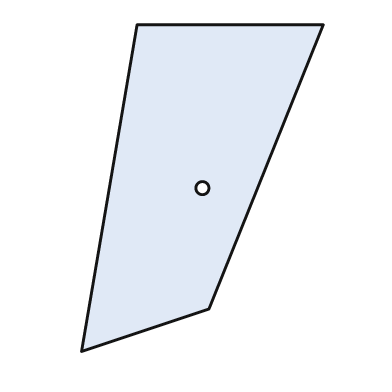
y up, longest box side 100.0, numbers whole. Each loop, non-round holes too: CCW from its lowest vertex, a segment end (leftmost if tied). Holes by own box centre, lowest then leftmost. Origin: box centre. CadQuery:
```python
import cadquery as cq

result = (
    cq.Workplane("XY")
    .moveTo(-37.0, -50.0)
    .lineTo(2.0, -37.0)
    .lineTo(37.0, 50.0)
    .lineTo(-20.0, 50.0)
    .close()
    .moveTo(0.0, 0.0)
    .circle(2.0)
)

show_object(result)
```